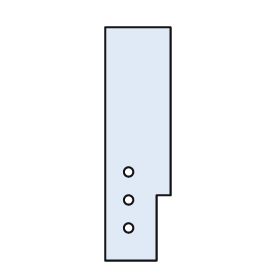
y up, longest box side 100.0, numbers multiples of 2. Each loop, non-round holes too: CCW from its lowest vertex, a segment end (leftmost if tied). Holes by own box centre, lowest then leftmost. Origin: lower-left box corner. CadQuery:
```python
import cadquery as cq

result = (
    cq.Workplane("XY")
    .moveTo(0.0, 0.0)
    .lineTo(22.0, 0.0)
    .lineTo(22.0, 28.0)
    .lineTo(28.0, 28.0)
    .lineTo(28.0, 100.0)
    .lineTo(0.0, 100.0)
    .close()
    .moveTo(10.0, 14.0)
    .circle(2.0)
    .moveTo(10.0, 26.0)
    .circle(2.0)
    .moveTo(10.0, 38.0)
    .circle(2.0)
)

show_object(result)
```